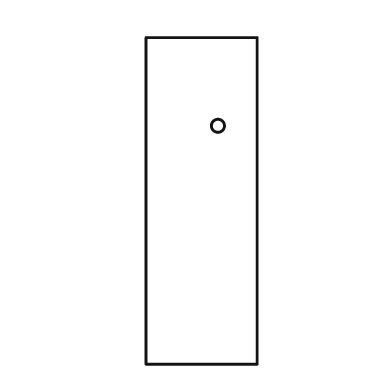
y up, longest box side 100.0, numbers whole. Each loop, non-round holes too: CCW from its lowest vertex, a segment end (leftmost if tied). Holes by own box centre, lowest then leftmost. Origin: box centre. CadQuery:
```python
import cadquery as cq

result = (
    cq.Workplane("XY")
    .moveTo(-17.0, -50.0)
    .lineTo(17.0, -50.0)
    .lineTo(17.0, 50.0)
    .lineTo(-17.0, 50.0)
    .close()
    .moveTo(5.0, 23.0)
    .circle(2.0)
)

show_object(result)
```